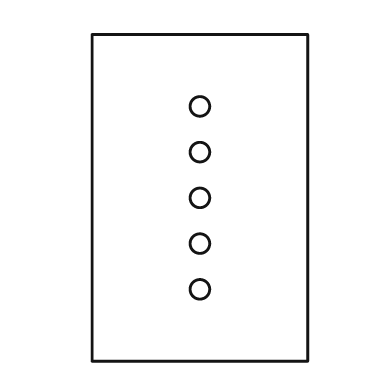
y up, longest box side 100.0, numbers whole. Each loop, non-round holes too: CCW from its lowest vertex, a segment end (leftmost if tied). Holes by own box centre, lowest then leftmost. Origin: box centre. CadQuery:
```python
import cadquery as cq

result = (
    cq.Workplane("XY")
    .moveTo(-33.0, -50.0)
    .lineTo(33.0, -50.0)
    .lineTo(33.0, 50.0)
    .lineTo(-33.0, 50.0)
    .close()
    .moveTo(0.0, -28.0)
    .circle(3.0)
    .moveTo(0.0, -14.0)
    .circle(3.0)
    .moveTo(0.0, 0.0)
    .circle(3.0)
    .moveTo(0.0, 14.0)
    .circle(3.0)
    .moveTo(0.0, 28.0)
    .circle(3.0)
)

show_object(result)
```